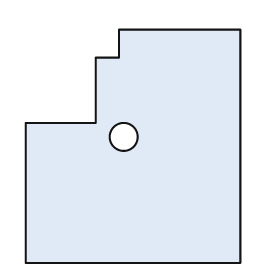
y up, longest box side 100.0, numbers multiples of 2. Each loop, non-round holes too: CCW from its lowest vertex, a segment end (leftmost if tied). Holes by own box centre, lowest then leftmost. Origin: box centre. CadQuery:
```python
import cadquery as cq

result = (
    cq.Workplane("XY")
    .moveTo(-46.0, -50.0)
    .lineTo(46.0, -50.0)
    .lineTo(46.0, 50.0)
    .lineTo(-6.0, 50.0)
    .lineTo(-6.0, 38.0)
    .lineTo(-16.0, 38.0)
    .lineTo(-16.0, 10.0)
    .lineTo(-46.0, 10.0)
    .close()
    .moveTo(-4.0, 4.0)
    .circle(6.0)
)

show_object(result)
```